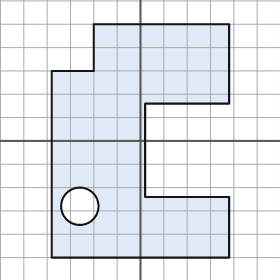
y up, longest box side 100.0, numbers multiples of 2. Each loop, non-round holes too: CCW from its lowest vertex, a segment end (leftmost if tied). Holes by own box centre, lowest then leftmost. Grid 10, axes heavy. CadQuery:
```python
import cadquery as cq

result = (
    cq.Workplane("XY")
    .moveTo(-38.0, -50.0)
    .lineTo(38.0, -50.0)
    .lineTo(38.0, -24.0)
    .lineTo(2.0, -24.0)
    .lineTo(2.0, 16.0)
    .lineTo(38.0, 16.0)
    .lineTo(38.0, 50.0)
    .lineTo(-20.0, 50.0)
    .lineTo(-20.0, 30.0)
    .lineTo(-38.0, 30.0)
    .close()
    .moveTo(-26.0, -28.0)
    .circle(8.0)
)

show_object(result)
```